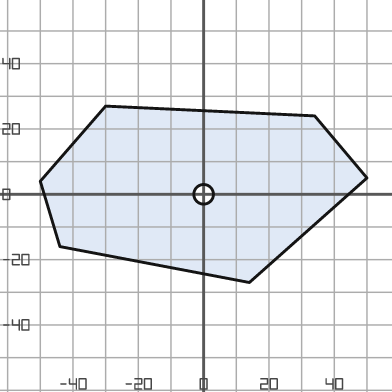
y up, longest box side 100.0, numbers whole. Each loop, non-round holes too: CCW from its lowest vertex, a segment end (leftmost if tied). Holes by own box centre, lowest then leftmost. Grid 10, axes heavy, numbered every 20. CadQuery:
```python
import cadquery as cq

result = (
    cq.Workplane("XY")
    .moveTo(14.0, -27.0)
    .lineTo(50.0, 5.0)
    .lineTo(34.0, 24.0)
    .lineTo(-30.0, 27.0)
    .lineTo(-50.0, 4.0)
    .lineTo(-44.0, -16.0)
    .close()
    .moveTo(0.0, 0.0)
    .circle(3.0)
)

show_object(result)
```